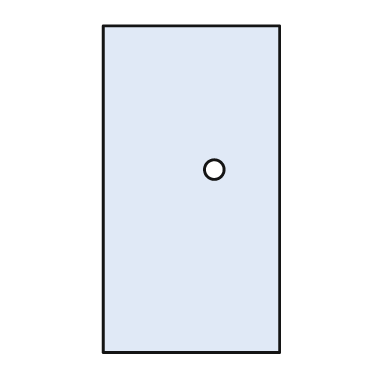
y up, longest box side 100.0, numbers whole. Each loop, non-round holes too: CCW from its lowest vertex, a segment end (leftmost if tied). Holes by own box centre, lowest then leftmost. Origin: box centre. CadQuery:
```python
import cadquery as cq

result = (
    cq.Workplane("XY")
    .moveTo(-27.0, -50.0)
    .lineTo(27.0, -50.0)
    .lineTo(27.0, 50.0)
    .lineTo(-27.0, 50.0)
    .close()
    .moveTo(7.0, 6.0)
    .circle(3.0)
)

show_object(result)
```